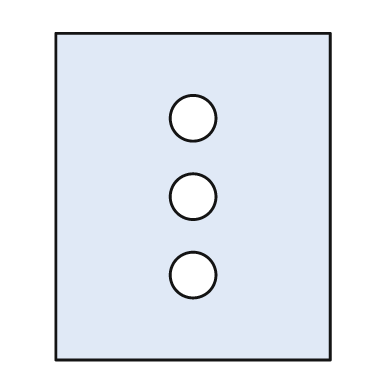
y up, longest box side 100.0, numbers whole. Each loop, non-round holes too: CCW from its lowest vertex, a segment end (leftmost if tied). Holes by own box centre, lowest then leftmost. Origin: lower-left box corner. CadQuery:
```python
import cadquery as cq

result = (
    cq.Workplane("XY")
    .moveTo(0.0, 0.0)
    .lineTo(84.0, 0.0)
    .lineTo(84.0, 100.0)
    .lineTo(0.0, 100.0)
    .close()
    .moveTo(42.0, 26.0)
    .circle(7.0)
    .moveTo(42.0, 50.0)
    .circle(7.0)
    .moveTo(42.0, 74.0)
    .circle(7.0)
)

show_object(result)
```